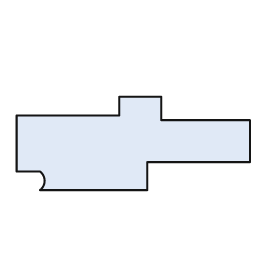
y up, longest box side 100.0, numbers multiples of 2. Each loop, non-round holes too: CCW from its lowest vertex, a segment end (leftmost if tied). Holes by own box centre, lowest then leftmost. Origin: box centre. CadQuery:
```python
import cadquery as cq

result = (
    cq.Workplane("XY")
    .moveTo(-40.0, -20.0)
    .lineTo(6.0, -20.0)
    .lineTo(6.0, -8.0)
    .lineTo(50.0, -8.0)
    .lineTo(50.0, 10.0)
    .lineTo(12.0, 10.0)
    .lineTo(12.0, 20.0)
    .lineTo(-6.0, 20.0)
    .lineTo(-6.0, 12.0)
    .lineTo(-50.0, 12.0)
    .lineTo(-50.0, -12.0)
    .lineTo(-40.0, -12.0)
    .threePointArc((-38.0, -16.0), (-40.0, -20.0))
    .close()
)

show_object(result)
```